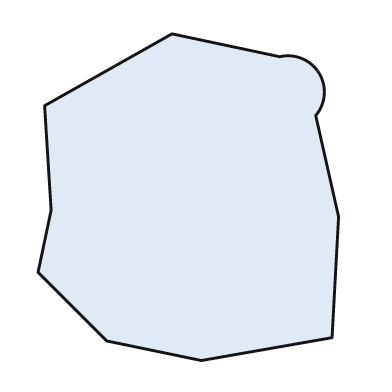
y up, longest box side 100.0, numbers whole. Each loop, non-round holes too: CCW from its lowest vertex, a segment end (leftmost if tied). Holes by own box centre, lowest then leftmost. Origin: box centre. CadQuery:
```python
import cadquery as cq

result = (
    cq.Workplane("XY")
    .moveTo(4.0, -50.0)
    .lineTo(44.0, -43.0)
    .lineTo(46.0, -6.0)
    .lineTo(39.0, 25.0)
    .threePointArc((40.0, 38.0), (28.0, 43.0))
    .lineTo(-5.0, 50.0)
    .lineTo(-44.0, 28.0)
    .lineTo(-42.0, -4.0)
    .lineTo(-46.0, -23.0)
    .lineTo(-25.0, -44.0)
    .close()
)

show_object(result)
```